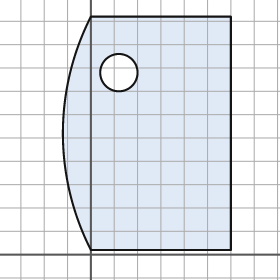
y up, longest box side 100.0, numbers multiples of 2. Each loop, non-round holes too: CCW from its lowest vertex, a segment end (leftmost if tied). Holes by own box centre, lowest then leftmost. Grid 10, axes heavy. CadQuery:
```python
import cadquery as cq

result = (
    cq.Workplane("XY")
    .moveTo(0.0, 2.0)
    .lineTo(60.0, 2.0)
    .lineTo(60.0, 102.0)
    .lineTo(0.0, 102.0)
    .threePointArc((-12.0, 52.0), (0.0, 2.0))
    .close()
    .moveTo(12.0, 78.0)
    .circle(8.0)
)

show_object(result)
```